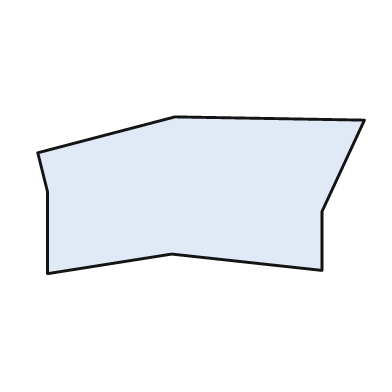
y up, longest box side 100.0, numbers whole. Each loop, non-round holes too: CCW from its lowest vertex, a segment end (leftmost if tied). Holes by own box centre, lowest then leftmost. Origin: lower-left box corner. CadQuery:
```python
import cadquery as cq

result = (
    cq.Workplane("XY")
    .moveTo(3.0, 0.0)
    .lineTo(41.0, 6.0)
    .lineTo(87.0, 1.0)
    .lineTo(87.0, 19.0)
    .lineTo(100.0, 47.0)
    .lineTo(42.0, 48.0)
    .lineTo(0.0, 37.0)
    .lineTo(3.0, 25.0)
    .close()
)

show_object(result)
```